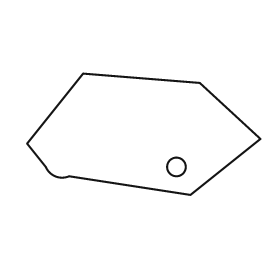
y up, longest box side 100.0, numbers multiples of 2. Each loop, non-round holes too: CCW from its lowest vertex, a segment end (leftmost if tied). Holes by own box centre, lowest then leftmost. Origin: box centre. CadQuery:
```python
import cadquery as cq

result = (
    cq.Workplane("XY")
    .moveTo(20.0, -26.0)
    .lineTo(50.0, -2.0)
    .lineTo(24.0, 22.0)
    .lineTo(-26.0, 26.0)
    .lineTo(-50.0, -4.0)
    .lineTo(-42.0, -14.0)
    .threePointArc((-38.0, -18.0), (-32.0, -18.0))
    .close()
    .moveTo(14.0, -14.0)
    .circle(4.0)
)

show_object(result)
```